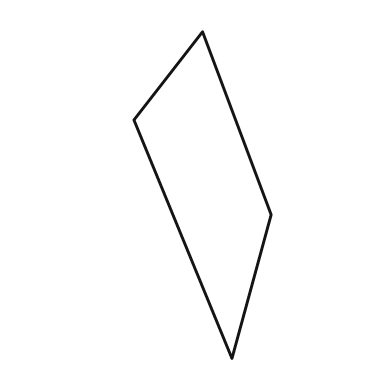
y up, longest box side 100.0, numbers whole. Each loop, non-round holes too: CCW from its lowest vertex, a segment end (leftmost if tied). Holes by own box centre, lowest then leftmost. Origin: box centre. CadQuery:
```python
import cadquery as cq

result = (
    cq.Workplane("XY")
    .moveTo(9.0, -50.0)
    .lineTo(21.0, -6.0)
    .lineTo(0.0, 50.0)
    .lineTo(-21.0, 23.0)
    .close()
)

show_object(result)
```